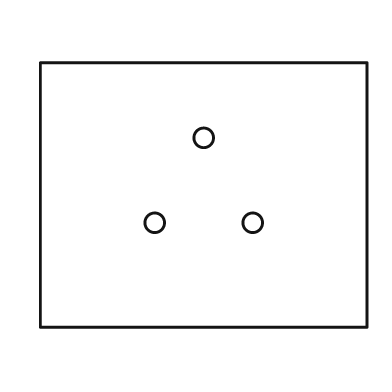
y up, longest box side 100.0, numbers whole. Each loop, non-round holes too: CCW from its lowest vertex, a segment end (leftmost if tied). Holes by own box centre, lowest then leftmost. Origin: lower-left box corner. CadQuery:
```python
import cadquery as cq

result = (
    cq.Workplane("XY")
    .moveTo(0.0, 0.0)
    .lineTo(100.0, 0.0)
    .lineTo(100.0, 81.0)
    .lineTo(0.0, 81.0)
    .close()
    .moveTo(35.0, 32.0)
    .circle(3.0)
    .moveTo(65.0, 32.0)
    .circle(3.0)
    .moveTo(50.0, 58.0)
    .circle(3.0)
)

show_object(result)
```